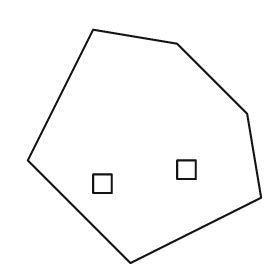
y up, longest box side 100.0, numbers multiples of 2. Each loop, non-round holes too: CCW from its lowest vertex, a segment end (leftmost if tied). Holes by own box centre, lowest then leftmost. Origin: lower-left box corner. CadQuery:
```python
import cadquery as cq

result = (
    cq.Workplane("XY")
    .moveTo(44.0, 0.0)
    .lineTo(100.0, 28.0)
    .lineTo(94.0, 64.0)
    .lineTo(64.0, 94.0)
    .lineTo(28.0, 100.0)
    .lineTo(0.0, 44.0)
    .close()
    .moveTo(28.0, 30.0)
    .lineTo(36.0, 30.0)
    .lineTo(36.0, 38.0)
    .lineTo(28.0, 38.0)
    .close()
    .moveTo(64.0, 36.0)
    .lineTo(72.0, 36.0)
    .lineTo(72.0, 44.0)
    .lineTo(64.0, 44.0)
    .close()
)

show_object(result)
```